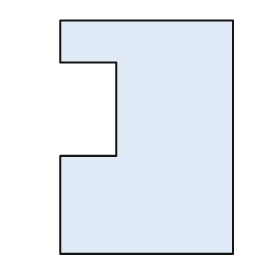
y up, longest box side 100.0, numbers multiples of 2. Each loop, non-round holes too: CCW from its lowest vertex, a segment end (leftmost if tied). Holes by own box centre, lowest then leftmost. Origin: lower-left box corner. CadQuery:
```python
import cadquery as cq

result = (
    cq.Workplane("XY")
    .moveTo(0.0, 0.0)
    .lineTo(74.0, 0.0)
    .lineTo(74.0, 100.0)
    .lineTo(0.0, 100.0)
    .lineTo(0.0, 82.0)
    .lineTo(24.0, 82.0)
    .lineTo(24.0, 42.0)
    .lineTo(0.0, 42.0)
    .close()
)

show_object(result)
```